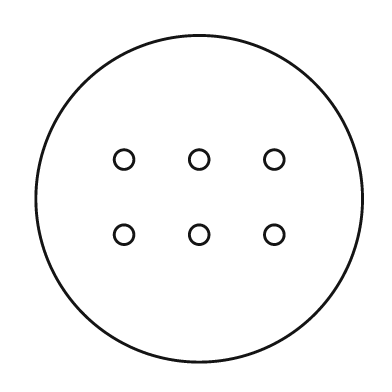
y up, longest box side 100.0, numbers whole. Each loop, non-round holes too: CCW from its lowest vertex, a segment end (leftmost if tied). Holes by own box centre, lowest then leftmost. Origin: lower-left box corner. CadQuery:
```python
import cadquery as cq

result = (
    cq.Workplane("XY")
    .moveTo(50.0, 50.0)
    .circle(50.0)
    .moveTo(27.0, 39.0)
    .circle(3.0)
    .moveTo(50.0, 39.0)
    .circle(3.0)
    .moveTo(73.0, 39.0)
    .circle(3.0)
    .moveTo(27.0, 62.0)
    .circle(3.0)
    .moveTo(50.0, 62.0)
    .circle(3.0)
    .moveTo(73.0, 62.0)
    .circle(3.0)
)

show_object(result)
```